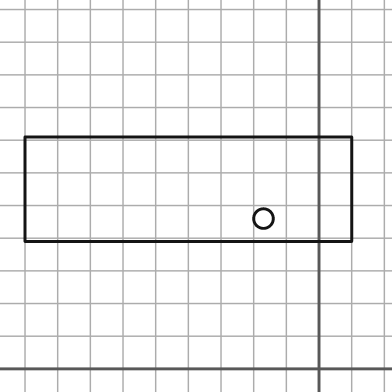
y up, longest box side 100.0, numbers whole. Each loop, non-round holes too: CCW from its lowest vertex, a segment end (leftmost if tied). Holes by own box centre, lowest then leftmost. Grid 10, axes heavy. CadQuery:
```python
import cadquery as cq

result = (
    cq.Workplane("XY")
    .moveTo(-90.0, 39.0)
    .lineTo(10.0, 39.0)
    .lineTo(10.0, 71.0)
    .lineTo(-90.0, 71.0)
    .close()
    .moveTo(-17.0, 46.0)
    .circle(3.0)
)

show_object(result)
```